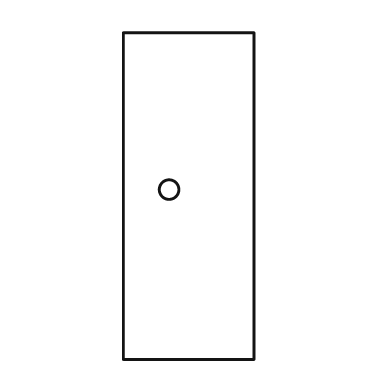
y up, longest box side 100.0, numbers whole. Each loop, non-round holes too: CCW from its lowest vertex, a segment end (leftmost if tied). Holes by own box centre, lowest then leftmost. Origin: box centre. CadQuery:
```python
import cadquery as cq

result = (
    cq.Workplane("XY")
    .moveTo(-20.0, -50.0)
    .lineTo(20.0, -50.0)
    .lineTo(20.0, 50.0)
    .lineTo(-20.0, 50.0)
    .close()
    .moveTo(-6.0, 2.0)
    .circle(3.0)
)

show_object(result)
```